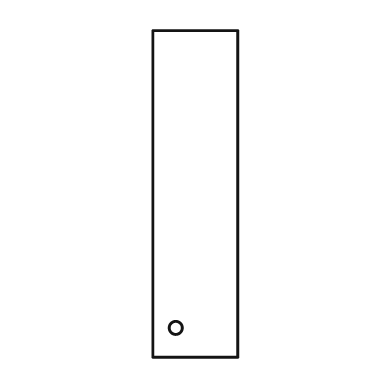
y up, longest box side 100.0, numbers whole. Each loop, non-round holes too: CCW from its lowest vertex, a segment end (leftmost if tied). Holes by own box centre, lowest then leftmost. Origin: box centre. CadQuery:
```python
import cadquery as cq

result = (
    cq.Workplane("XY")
    .moveTo(-13.0, -50.0)
    .lineTo(13.0, -50.0)
    .lineTo(13.0, 50.0)
    .lineTo(-13.0, 50.0)
    .close()
    .moveTo(-6.0, -41.0)
    .circle(2.0)
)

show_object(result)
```